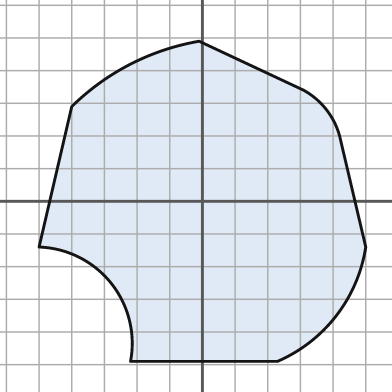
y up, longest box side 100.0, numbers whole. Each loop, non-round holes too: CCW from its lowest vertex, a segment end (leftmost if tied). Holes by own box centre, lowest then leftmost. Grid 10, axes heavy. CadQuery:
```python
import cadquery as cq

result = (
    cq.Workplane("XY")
    .moveTo(-22.0, -49.0)
    .lineTo(23.0, -49.0)
    .threePointArc((41.0, -35.0), (50.0, -14.0))
    .lineTo(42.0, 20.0)
    .threePointArc((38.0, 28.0), (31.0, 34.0))
    .lineTo(-1.0, 49.0)
    .threePointArc((-22.0, 42.0), (-40.0, 29.0))
    .lineTo(-50.0, -14.0)
    .threePointArc((-28.0, -25.0), (-22.0, -49.0))
    .close()
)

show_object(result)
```